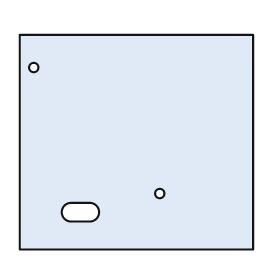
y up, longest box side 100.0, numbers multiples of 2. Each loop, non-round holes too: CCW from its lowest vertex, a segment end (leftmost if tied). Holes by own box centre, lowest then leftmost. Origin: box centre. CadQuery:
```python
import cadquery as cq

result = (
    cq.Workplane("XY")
    .moveTo(-50.0, -46.0)
    .lineTo(50.0, -46.0)
    .lineTo(50.0, 46.0)
    .lineTo(-50.0, 46.0)
    .close()
    .moveTo(-28.0, -34.0)
    .lineTo(-20.0, -34.0)
    .threePointArc((-16.0, -30.0), (-20.0, -26.0))
    .lineTo(-28.0, -26.0)
    .threePointArc((-32.0, -30.0), (-28.0, -34.0))
    .close()
    .moveTo(10.0, -22.0)
    .circle(2.0)
    .moveTo(-44.0, 32.0)
    .circle(2.0)
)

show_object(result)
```